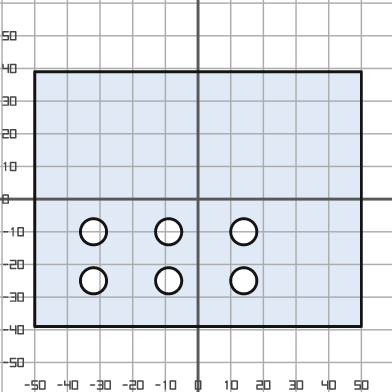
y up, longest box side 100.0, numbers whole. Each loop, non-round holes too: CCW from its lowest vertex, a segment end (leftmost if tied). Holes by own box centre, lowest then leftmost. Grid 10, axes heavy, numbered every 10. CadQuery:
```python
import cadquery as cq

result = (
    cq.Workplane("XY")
    .moveTo(-50.0, -39.0)
    .lineTo(50.0, -39.0)
    .lineTo(50.0, 39.0)
    .lineTo(-50.0, 39.0)
    .close()
    .moveTo(-32.0, -25.0)
    .circle(4.0)
    .moveTo(-9.0, -25.0)
    .circle(4.0)
    .moveTo(14.0, -25.0)
    .circle(4.0)
    .moveTo(-32.0, -10.0)
    .circle(4.0)
    .moveTo(-9.0, -10.0)
    .circle(4.0)
    .moveTo(14.0, -10.0)
    .circle(4.0)
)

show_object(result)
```